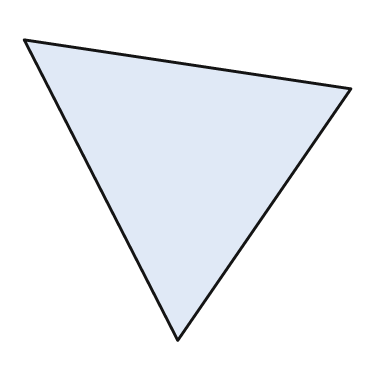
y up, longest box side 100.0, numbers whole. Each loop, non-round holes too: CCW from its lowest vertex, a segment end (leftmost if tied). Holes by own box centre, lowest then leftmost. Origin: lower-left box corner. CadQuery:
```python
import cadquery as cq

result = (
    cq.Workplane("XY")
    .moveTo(47.0, 0.0)
    .lineTo(100.0, 77.0)
    .lineTo(0.0, 92.0)
    .close()
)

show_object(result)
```